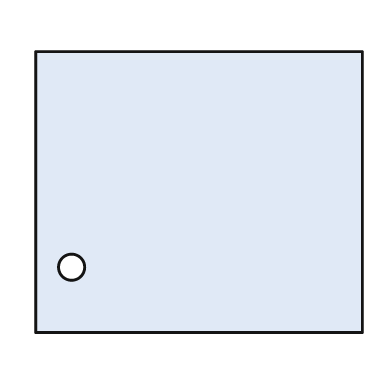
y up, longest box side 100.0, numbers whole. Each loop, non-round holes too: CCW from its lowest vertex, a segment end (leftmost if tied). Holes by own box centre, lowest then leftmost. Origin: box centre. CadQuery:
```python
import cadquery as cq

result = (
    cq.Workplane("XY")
    .moveTo(-50.0, -43.0)
    .lineTo(50.0, -43.0)
    .lineTo(50.0, 43.0)
    .lineTo(-50.0, 43.0)
    .close()
    .moveTo(-39.0, -23.0)
    .circle(4.0)
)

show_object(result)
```